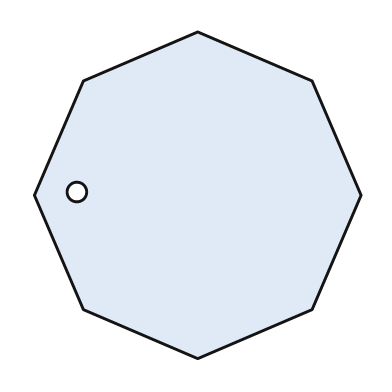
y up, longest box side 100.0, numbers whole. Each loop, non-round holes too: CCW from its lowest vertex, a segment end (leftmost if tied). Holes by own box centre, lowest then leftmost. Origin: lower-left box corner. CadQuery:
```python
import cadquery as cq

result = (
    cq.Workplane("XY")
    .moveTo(50.0, 0.0)
    .lineTo(85.0, 15.0)
    .lineTo(100.0, 50.0)
    .lineTo(85.0, 85.0)
    .lineTo(50.0, 100.0)
    .lineTo(15.0, 85.0)
    .lineTo(0.0, 50.0)
    .lineTo(15.0, 15.0)
    .close()
    .moveTo(13.0, 51.0)
    .circle(3.0)
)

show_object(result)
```